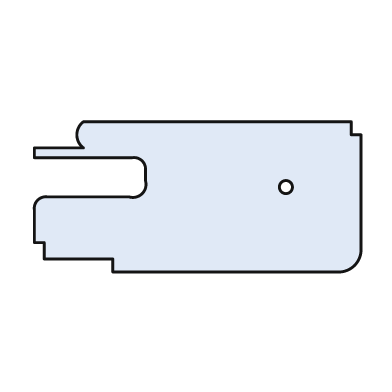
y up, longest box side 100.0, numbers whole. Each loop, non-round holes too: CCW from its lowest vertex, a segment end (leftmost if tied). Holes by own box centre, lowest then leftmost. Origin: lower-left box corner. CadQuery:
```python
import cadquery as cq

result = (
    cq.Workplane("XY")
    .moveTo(24.0, 0.0)
    .lineTo(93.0, 0.0)
    .threePointArc((98.0, 2.0), (100.0, 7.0))
    .lineTo(100.0, 42.0)
    .lineTo(97.0, 42.0)
    .lineTo(97.0, 46.0)
    .lineTo(15.0, 46.0)
    .threePointArc((13.0, 42.0), (15.0, 38.0))
    .lineTo(0.0, 38.0)
    .lineTo(0.0, 35.0)
    .lineTo(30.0, 35.0)
    .threePointArc((33.0, 34.0), (34.0, 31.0))
    .lineTo(34.0, 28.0)
    .threePointArc((33.0, 24.0), (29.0, 23.0))
    .lineTo(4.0, 23.0)
    .threePointArc((1.0, 22.0), (0.0, 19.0))
    .lineTo(0.0, 9.0)
    .lineTo(3.0, 9.0)
    .lineTo(3.0, 4.0)
    .lineTo(24.0, 4.0)
    .close()
    .moveTo(77.0, 26.0)
    .circle(2.0)
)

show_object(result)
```